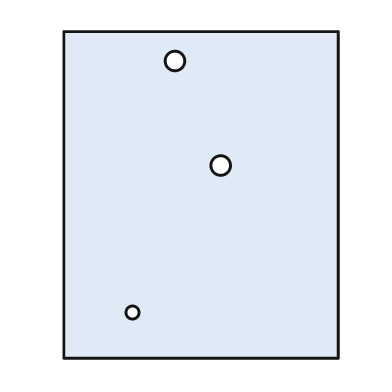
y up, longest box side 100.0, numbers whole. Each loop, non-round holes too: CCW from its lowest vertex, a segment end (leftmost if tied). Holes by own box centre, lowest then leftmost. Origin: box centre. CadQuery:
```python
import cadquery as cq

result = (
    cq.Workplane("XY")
    .moveTo(-42.0, -50.0)
    .lineTo(42.0, -50.0)
    .lineTo(42.0, 50.0)
    .lineTo(-42.0, 50.0)
    .close()
    .moveTo(-21.0, -36.0)
    .circle(2.0)
    .moveTo(6.0, 9.0)
    .circle(3.0)
    .moveTo(-8.0, 41.0)
    .circle(3.0)
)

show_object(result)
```